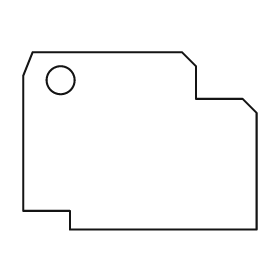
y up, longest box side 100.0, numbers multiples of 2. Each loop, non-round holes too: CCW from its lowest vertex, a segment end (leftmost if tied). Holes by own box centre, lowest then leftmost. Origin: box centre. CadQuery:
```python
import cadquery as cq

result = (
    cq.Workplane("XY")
    .moveTo(-30.0, -38.0)
    .lineTo(50.0, -38.0)
    .lineTo(50.0, 12.0)
    .lineTo(44.0, 18.0)
    .lineTo(24.0, 18.0)
    .lineTo(24.0, 32.0)
    .lineTo(18.0, 38.0)
    .lineTo(-46.0, 38.0)
    .lineTo(-50.0, 28.0)
    .lineTo(-50.0, -30.0)
    .lineTo(-30.0, -30.0)
    .close()
    .moveTo(-34.0, 26.0)
    .circle(6.0)
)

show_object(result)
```